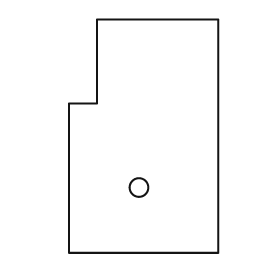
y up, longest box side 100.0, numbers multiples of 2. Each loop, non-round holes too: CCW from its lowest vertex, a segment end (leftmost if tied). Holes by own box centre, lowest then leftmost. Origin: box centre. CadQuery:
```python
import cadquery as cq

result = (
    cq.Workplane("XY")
    .moveTo(-32.0, -50.0)
    .lineTo(32.0, -50.0)
    .lineTo(32.0, 50.0)
    .lineTo(-20.0, 50.0)
    .lineTo(-20.0, 14.0)
    .lineTo(-32.0, 14.0)
    .close()
    .moveTo(-2.0, -22.0)
    .circle(4.0)
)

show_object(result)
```